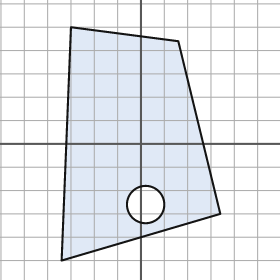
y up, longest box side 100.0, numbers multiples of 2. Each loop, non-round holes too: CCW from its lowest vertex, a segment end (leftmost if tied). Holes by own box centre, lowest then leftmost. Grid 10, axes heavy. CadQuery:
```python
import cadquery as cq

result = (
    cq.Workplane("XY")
    .moveTo(-34.0, -50.0)
    .lineTo(34.0, -30.0)
    .lineTo(16.0, 44.0)
    .lineTo(-30.0, 50.0)
    .close()
    .moveTo(2.0, -26.0)
    .circle(8.0)
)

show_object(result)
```